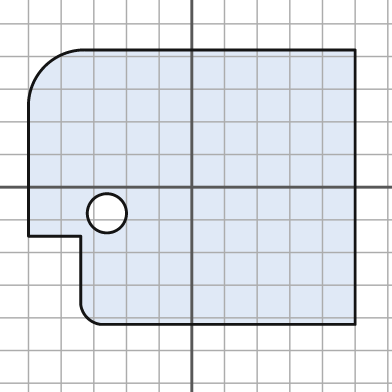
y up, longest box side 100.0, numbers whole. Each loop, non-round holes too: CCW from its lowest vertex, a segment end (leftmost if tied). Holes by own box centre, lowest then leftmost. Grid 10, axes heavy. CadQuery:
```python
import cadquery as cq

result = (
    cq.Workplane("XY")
    .moveTo(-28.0, -42.0)
    .lineTo(50.0, -42.0)
    .lineTo(50.0, 42.0)
    .lineTo(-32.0, 42.0)
    .threePointArc((-45.0, 37.0), (-50.0, 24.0))
    .lineTo(-50.0, -15.0)
    .lineTo(-34.0, -15.0)
    .lineTo(-34.0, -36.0)
    .threePointArc((-32.0, -40.0), (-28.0, -42.0))
    .close()
    .moveTo(-26.0, -8.0)
    .circle(6.0)
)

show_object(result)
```